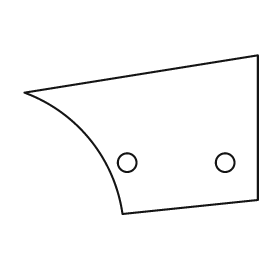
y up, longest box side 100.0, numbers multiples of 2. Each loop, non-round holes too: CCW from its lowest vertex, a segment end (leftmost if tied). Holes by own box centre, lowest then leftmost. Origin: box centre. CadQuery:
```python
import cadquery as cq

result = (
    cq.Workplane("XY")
    .moveTo(-8.0, -34.0)
    .lineTo(50.0, -28.0)
    .lineTo(50.0, 34.0)
    .lineTo(-50.0, 18.0)
    .threePointArc((-22.0, -2.0), (-8.0, -34.0))
    .close()
    .moveTo(-6.0, -12.0)
    .circle(4.0)
    .moveTo(36.0, -12.0)
    .circle(4.0)
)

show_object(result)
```